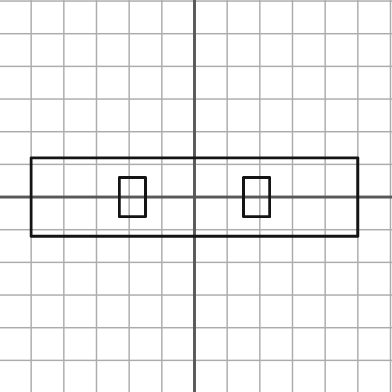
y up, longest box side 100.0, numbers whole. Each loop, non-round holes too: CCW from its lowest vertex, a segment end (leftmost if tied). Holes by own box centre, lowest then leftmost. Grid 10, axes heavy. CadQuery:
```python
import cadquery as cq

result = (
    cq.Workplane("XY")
    .moveTo(-50.0, -12.0)
    .lineTo(50.0, -12.0)
    .lineTo(50.0, 12.0)
    .lineTo(-50.0, 12.0)
    .close()
    .moveTo(-23.0, -6.0)
    .lineTo(-15.0, -6.0)
    .lineTo(-15.0, 6.0)
    .lineTo(-23.0, 6.0)
    .close()
    .moveTo(15.0, -6.0)
    .lineTo(23.0, -6.0)
    .lineTo(23.0, 6.0)
    .lineTo(15.0, 6.0)
    .close()
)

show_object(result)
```